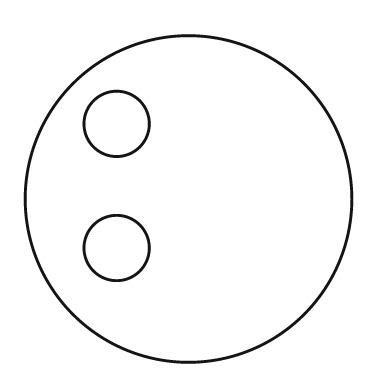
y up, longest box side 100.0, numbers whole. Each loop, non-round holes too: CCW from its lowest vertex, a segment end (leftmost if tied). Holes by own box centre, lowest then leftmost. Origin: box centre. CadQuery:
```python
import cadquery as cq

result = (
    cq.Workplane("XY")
    .moveTo(0.0, 0.0)
    .circle(50.0)
    .moveTo(-22.0, -15.0)
    .circle(10.0)
    .moveTo(-22.0, 23.0)
    .circle(10.0)
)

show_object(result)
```